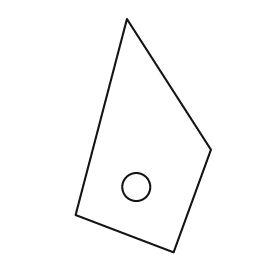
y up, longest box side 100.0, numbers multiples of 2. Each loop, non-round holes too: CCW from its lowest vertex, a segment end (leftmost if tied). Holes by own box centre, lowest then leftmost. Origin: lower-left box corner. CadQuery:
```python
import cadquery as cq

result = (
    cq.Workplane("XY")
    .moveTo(42.0, 0.0)
    .lineTo(58.0, 44.0)
    .lineTo(22.0, 100.0)
    .lineTo(0.0, 16.0)
    .close()
    .moveTo(26.0, 28.0)
    .circle(6.0)
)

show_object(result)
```